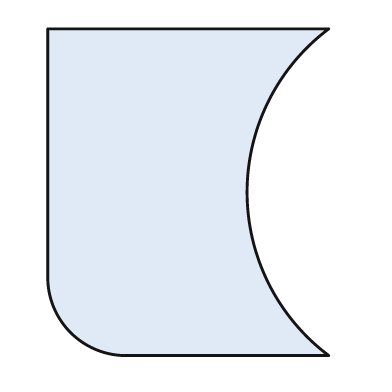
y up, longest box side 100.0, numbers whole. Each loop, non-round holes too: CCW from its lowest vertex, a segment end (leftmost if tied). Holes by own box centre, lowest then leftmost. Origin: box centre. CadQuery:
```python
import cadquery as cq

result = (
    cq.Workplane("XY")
    .moveTo(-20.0, -50.0)
    .lineTo(43.0, -50.0)
    .threePointArc((18.0, 0.0), (43.0, 50.0))
    .lineTo(-43.0, 50.0)
    .lineTo(-43.0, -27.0)
    .threePointArc((-36.0, -43.0), (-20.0, -50.0))
    .close()
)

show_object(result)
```